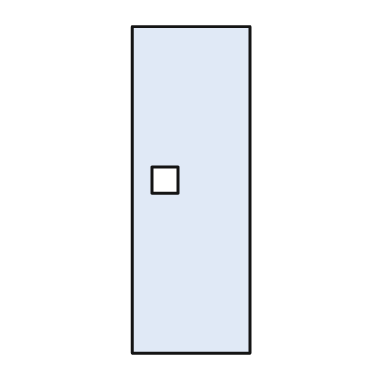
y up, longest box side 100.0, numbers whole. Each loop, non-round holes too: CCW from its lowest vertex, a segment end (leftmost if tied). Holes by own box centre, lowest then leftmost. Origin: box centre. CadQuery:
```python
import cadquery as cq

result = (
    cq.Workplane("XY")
    .moveTo(-18.0, -50.0)
    .lineTo(18.0, -50.0)
    .lineTo(18.0, 50.0)
    .lineTo(-18.0, 50.0)
    .close()
    .moveTo(-12.0, -1.0)
    .lineTo(-4.0, -1.0)
    .lineTo(-4.0, 7.0)
    .lineTo(-12.0, 7.0)
    .close()
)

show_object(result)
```